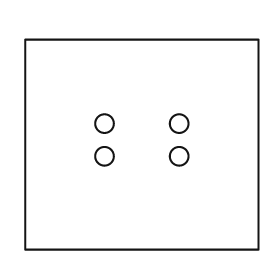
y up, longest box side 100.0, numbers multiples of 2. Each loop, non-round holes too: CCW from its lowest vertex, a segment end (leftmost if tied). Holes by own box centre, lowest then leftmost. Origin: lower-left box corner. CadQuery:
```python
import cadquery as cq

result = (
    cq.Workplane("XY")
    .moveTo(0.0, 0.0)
    .lineTo(100.0, 0.0)
    .lineTo(100.0, 90.0)
    .lineTo(0.0, 90.0)
    .close()
    .moveTo(34.0, 40.0)
    .circle(4.0)
    .moveTo(66.0, 40.0)
    .circle(4.0)
    .moveTo(34.0, 54.0)
    .circle(4.0)
    .moveTo(66.0, 54.0)
    .circle(4.0)
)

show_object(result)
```